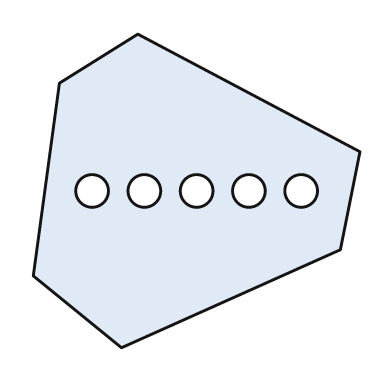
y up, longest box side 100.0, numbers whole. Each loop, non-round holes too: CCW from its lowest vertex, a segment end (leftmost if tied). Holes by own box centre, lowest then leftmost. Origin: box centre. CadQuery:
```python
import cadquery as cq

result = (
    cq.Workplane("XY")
    .moveTo(-23.0, -48.0)
    .lineTo(44.0, -18.0)
    .lineTo(50.0, 12.0)
    .lineTo(-18.0, 48.0)
    .lineTo(-42.0, 33.0)
    .lineTo(-50.0, -26.0)
    .close()
    .moveTo(-32.0, 0.0)
    .circle(5.0)
    .moveTo(-16.0, 0.0)
    .circle(5.0)
    .moveTo(0.0, 0.0)
    .circle(5.0)
    .moveTo(16.0, 0.0)
    .circle(5.0)
    .moveTo(32.0, 0.0)
    .circle(5.0)
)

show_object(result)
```